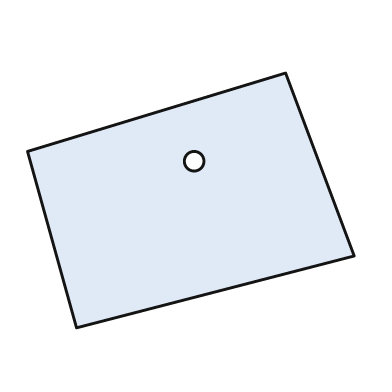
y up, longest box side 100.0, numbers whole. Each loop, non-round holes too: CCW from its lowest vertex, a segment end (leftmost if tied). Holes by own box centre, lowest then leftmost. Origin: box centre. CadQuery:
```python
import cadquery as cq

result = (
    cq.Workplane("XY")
    .moveTo(-35.0, -39.0)
    .lineTo(50.0, -17.0)
    .lineTo(29.0, 39.0)
    .lineTo(-50.0, 15.0)
    .close()
    .moveTo(1.0, 12.0)
    .circle(3.0)
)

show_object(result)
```